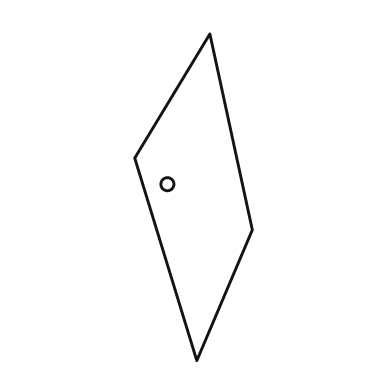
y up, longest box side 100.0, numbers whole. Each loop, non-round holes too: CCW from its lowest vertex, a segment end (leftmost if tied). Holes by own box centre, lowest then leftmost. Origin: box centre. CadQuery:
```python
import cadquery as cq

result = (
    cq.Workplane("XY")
    .moveTo(1.0, -50.0)
    .lineTo(18.0, -10.0)
    .lineTo(5.0, 50.0)
    .lineTo(-18.0, 12.0)
    .close()
    .moveTo(-8.0, 4.0)
    .circle(2.0)
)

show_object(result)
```